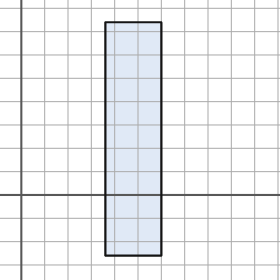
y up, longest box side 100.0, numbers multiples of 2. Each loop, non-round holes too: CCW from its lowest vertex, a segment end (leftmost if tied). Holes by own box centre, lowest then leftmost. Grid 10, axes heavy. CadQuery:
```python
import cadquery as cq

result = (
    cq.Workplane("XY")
    .moveTo(36.0, -26.0)
    .lineTo(60.0, -26.0)
    .lineTo(60.0, 74.0)
    .lineTo(36.0, 74.0)
    .close()
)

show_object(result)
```